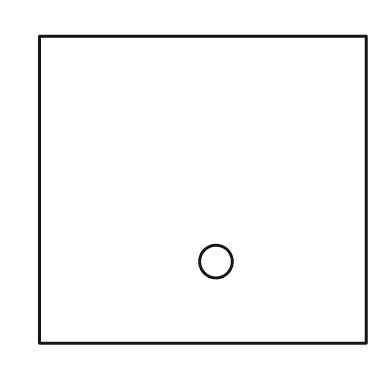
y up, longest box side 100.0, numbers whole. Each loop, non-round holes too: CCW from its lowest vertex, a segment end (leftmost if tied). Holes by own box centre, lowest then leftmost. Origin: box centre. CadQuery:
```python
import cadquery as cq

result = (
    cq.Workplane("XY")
    .moveTo(-50.0, -47.0)
    .lineTo(50.0, -47.0)
    .lineTo(50.0, 47.0)
    .lineTo(-50.0, 47.0)
    .close()
    .moveTo(4.0, -22.0)
    .circle(5.0)
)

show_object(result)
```